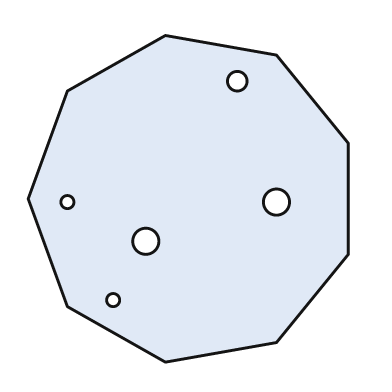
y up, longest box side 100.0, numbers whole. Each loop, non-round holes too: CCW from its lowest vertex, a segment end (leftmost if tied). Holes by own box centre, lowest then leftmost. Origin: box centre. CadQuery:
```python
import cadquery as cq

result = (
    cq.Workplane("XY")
    .moveTo(-7.0, -50.0)
    .lineTo(27.0, -44.0)
    .lineTo(49.0, -17.0)
    .lineTo(49.0, 17.0)
    .lineTo(27.0, 44.0)
    .lineTo(-7.0, 50.0)
    .lineTo(-37.0, 33.0)
    .lineTo(-49.0, 0.0)
    .lineTo(-37.0, -33.0)
    .close()
    .moveTo(-23.0, -31.0)
    .circle(2.0)
    .moveTo(-13.0, -13.0)
    .circle(4.0)
    .moveTo(-37.0, -1.0)
    .circle(2.0)
    .moveTo(27.0, -1.0)
    .circle(4.0)
    .moveTo(15.0, 36.0)
    .circle(3.0)
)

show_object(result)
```